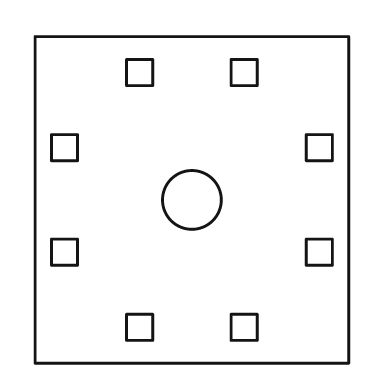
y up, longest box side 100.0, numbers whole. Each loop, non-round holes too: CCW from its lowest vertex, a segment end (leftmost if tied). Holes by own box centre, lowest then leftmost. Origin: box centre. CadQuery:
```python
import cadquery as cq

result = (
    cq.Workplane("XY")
    .moveTo(-48.0, -50.0)
    .lineTo(48.0, -50.0)
    .lineTo(48.0, 50.0)
    .lineTo(-48.0, 50.0)
    .close()
    .moveTo(-20.0, -43.0)
    .lineTo(-12.0, -43.0)
    .lineTo(-12.0, -35.0)
    .lineTo(-20.0, -35.0)
    .close()
    .moveTo(12.0, -43.0)
    .lineTo(20.0, -43.0)
    .lineTo(20.0, -35.0)
    .lineTo(12.0, -35.0)
    .close()
    .moveTo(-43.0, -20.0)
    .lineTo(-35.0, -20.0)
    .lineTo(-35.0, -12.0)
    .lineTo(-43.0, -12.0)
    .close()
    .moveTo(35.0, -20.0)
    .lineTo(43.0, -20.0)
    .lineTo(43.0, -12.0)
    .lineTo(35.0, -12.0)
    .close()
    .moveTo(0.0, 0.0)
    .circle(9.0)
    .moveTo(-43.0, 12.0)
    .lineTo(-35.0, 12.0)
    .lineTo(-35.0, 20.0)
    .lineTo(-43.0, 20.0)
    .close()
    .moveTo(35.0, 12.0)
    .lineTo(43.0, 12.0)
    .lineTo(43.0, 20.0)
    .lineTo(35.0, 20.0)
    .close()
    .moveTo(-20.0, 35.0)
    .lineTo(-12.0, 35.0)
    .lineTo(-12.0, 43.0)
    .lineTo(-20.0, 43.0)
    .close()
    .moveTo(12.0, 35.0)
    .lineTo(20.0, 35.0)
    .lineTo(20.0, 43.0)
    .lineTo(12.0, 43.0)
    .close()
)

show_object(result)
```